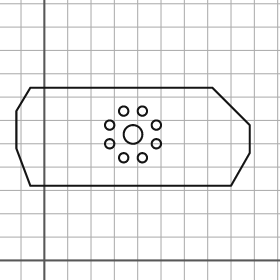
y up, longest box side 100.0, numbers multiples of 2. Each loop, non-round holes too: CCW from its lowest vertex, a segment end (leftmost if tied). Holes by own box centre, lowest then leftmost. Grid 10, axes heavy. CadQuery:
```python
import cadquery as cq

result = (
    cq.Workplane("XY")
    .moveTo(-6.0, 32.0)
    .lineTo(80.0, 32.0)
    .lineTo(88.0, 46.0)
    .lineTo(88.0, 58.0)
    .lineTo(72.0, 74.0)
    .lineTo(-6.0, 74.0)
    .lineTo(-12.0, 64.0)
    .lineTo(-12.0, 48.0)
    .close()
    .moveTo(34.0, 44.0)
    .circle(2.0)
    .moveTo(42.0, 44.0)
    .circle(2.0)
    .moveTo(28.0, 50.0)
    .circle(2.0)
    .moveTo(48.0, 50.0)
    .circle(2.0)
    .moveTo(38.0, 54.0)
    .circle(4.0)
    .moveTo(28.0, 58.0)
    .circle(2.0)
    .moveTo(48.0, 58.0)
    .circle(2.0)
    .moveTo(34.0, 64.0)
    .circle(2.0)
    .moveTo(42.0, 64.0)
    .circle(2.0)
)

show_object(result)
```